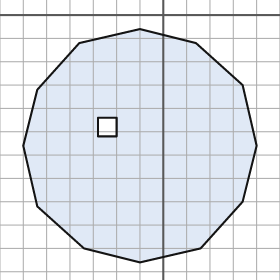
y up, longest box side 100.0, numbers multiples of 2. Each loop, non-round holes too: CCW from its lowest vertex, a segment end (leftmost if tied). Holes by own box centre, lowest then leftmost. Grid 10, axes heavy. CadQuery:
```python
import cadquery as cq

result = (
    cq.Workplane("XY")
    .moveTo(-10.0, -106.0)
    .lineTo(16.0, -100.0)
    .lineTo(34.0, -80.0)
    .lineTo(40.0, -56.0)
    .lineTo(34.0, -30.0)
    .lineTo(14.0, -12.0)
    .lineTo(-10.0, -6.0)
    .lineTo(-36.0, -12.0)
    .lineTo(-54.0, -32.0)
    .lineTo(-60.0, -56.0)
    .lineTo(-54.0, -82.0)
    .lineTo(-34.0, -100.0)
    .close()
    .moveTo(-28.0, -52.0)
    .lineTo(-20.0, -52.0)
    .lineTo(-20.0, -44.0)
    .lineTo(-28.0, -44.0)
    .close()
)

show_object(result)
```